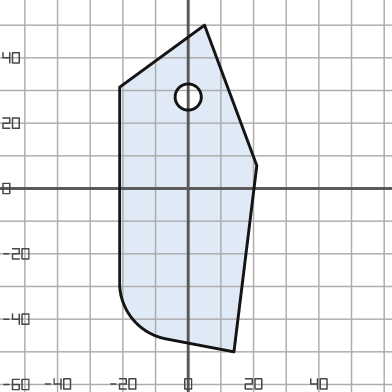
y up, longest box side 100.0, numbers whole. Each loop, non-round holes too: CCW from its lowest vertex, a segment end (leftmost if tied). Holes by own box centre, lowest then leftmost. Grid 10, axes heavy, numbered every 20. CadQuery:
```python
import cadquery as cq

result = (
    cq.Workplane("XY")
    .moveTo(14.0, -50.0)
    .lineTo(21.0, 7.0)
    .lineTo(5.0, 50.0)
    .lineTo(-21.0, 31.0)
    .lineTo(-21.0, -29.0)
    .threePointArc((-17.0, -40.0), (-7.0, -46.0))
    .close()
    .moveTo(0.0, 28.0)
    .circle(4.0)
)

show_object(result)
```